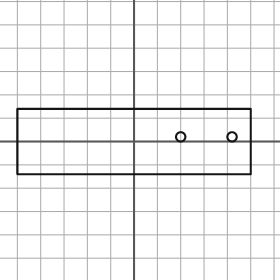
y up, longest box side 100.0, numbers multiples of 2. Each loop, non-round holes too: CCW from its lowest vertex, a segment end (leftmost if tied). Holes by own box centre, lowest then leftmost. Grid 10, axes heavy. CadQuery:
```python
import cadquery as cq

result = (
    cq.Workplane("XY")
    .moveTo(-50.0, -14.0)
    .lineTo(50.0, -14.0)
    .lineTo(50.0, 14.0)
    .lineTo(-50.0, 14.0)
    .close()
    .moveTo(20.0, 2.0)
    .circle(2.0)
    .moveTo(42.0, 2.0)
    .circle(2.0)
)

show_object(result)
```